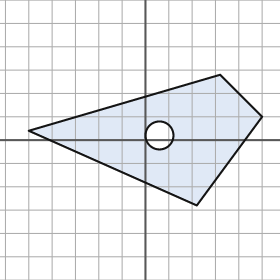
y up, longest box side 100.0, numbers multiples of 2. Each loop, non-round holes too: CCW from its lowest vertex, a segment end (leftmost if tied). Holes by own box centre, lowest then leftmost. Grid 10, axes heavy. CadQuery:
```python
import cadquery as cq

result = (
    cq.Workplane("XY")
    .moveTo(22.0, -28.0)
    .lineTo(50.0, 10.0)
    .lineTo(32.0, 28.0)
    .lineTo(-50.0, 4.0)
    .close()
    .moveTo(6.0, 2.0)
    .circle(6.0)
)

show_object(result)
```